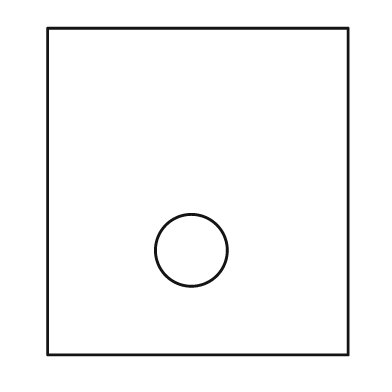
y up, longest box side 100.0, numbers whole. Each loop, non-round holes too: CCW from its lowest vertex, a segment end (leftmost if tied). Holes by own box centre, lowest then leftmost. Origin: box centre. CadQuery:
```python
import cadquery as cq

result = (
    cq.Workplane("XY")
    .moveTo(-46.0, -50.0)
    .lineTo(46.0, -50.0)
    .lineTo(46.0, 50.0)
    .lineTo(-46.0, 50.0)
    .close()
    .moveTo(-2.0, -18.0)
    .circle(11.0)
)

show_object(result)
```